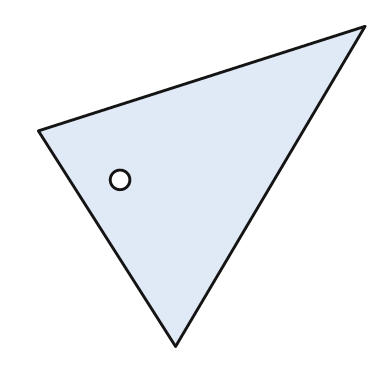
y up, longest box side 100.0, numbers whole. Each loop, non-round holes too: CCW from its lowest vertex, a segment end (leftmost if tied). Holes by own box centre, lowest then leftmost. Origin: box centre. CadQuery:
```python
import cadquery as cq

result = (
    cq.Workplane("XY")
    .moveTo(-8.0, -49.0)
    .lineTo(50.0, 49.0)
    .lineTo(-50.0, 17.0)
    .close()
    .moveTo(-25.0, 2.0)
    .circle(3.0)
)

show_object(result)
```